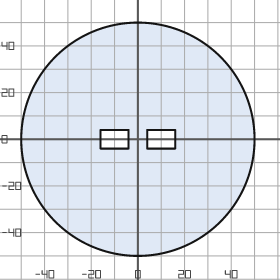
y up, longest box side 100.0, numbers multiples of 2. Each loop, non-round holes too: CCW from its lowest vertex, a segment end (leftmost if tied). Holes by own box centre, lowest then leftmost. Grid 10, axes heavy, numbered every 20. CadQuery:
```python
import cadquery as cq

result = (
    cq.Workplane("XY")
    .moveTo(0.0, 0.0)
    .circle(50.0)
    .moveTo(-16.0, -4.0)
    .lineTo(-4.0, -4.0)
    .lineTo(-4.0, 4.0)
    .lineTo(-16.0, 4.0)
    .close()
    .moveTo(4.0, -4.0)
    .lineTo(16.0, -4.0)
    .lineTo(16.0, 4.0)
    .lineTo(4.0, 4.0)
    .close()
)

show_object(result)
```